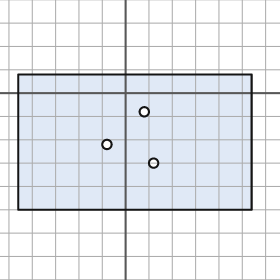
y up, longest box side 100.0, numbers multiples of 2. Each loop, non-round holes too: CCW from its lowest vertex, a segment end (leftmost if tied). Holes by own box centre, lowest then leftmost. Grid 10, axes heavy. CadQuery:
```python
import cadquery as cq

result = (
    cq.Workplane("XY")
    .moveTo(-46.0, -50.0)
    .lineTo(54.0, -50.0)
    .lineTo(54.0, 8.0)
    .lineTo(-46.0, 8.0)
    .close()
    .moveTo(12.0, -30.0)
    .circle(2.0)
    .moveTo(-8.0, -22.0)
    .circle(2.0)
    .moveTo(8.0, -8.0)
    .circle(2.0)
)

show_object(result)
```